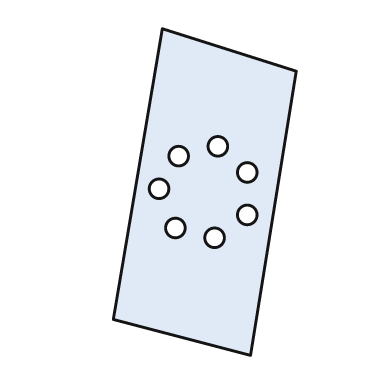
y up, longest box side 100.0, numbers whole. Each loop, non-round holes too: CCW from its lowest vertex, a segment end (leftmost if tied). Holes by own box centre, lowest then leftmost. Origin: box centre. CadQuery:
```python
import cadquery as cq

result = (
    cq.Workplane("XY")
    .moveTo(14.0, -50.0)
    .lineTo(28.0, 37.0)
    .lineTo(-13.0, 50.0)
    .lineTo(-28.0, -39.0)
    .close()
    .moveTo(3.0, -14.0)
    .circle(3.0)
    .moveTo(-9.0, -11.0)
    .circle(3.0)
    .moveTo(13.0, -7.0)
    .circle(3.0)
    .moveTo(-14.0, 1.0)
    .circle(3.0)
    .moveTo(13.0, 6.0)
    .circle(3.0)
    .moveTo(-8.0, 11.0)
    .circle(3.0)
    .moveTo(4.0, 14.0)
    .circle(3.0)
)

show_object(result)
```